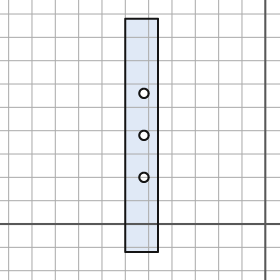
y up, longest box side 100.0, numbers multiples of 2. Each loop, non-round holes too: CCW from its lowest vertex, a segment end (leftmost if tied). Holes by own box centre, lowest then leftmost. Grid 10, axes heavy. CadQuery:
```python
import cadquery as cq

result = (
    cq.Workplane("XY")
    .moveTo(-60.0, -12.0)
    .lineTo(-46.0, -12.0)
    .lineTo(-46.0, 88.0)
    .lineTo(-60.0, 88.0)
    .close()
    .moveTo(-52.0, 20.0)
    .circle(2.0)
    .moveTo(-52.0, 38.0)
    .circle(2.0)
    .moveTo(-52.0, 56.0)
    .circle(2.0)
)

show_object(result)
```